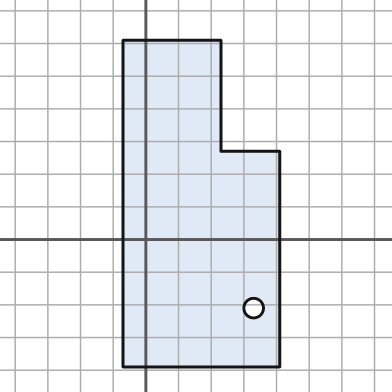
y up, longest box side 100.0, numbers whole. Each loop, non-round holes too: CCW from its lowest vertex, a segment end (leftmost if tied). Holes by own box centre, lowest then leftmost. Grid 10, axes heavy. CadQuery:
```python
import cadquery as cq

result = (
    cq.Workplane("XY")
    .moveTo(-7.0, -39.0)
    .lineTo(41.0, -39.0)
    .lineTo(41.0, 27.0)
    .lineTo(23.0, 27.0)
    .lineTo(23.0, 61.0)
    .lineTo(-7.0, 61.0)
    .close()
    .moveTo(33.0, -21.0)
    .circle(3.0)
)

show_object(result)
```